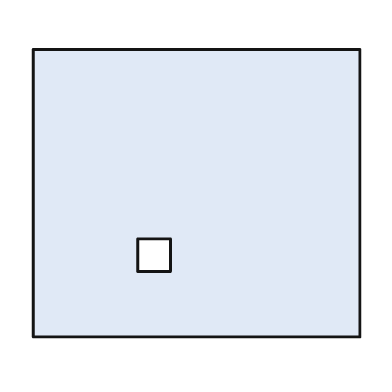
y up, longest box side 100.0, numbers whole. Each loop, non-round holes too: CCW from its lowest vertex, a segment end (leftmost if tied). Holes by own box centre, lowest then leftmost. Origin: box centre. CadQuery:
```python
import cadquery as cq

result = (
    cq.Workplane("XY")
    .moveTo(-50.0, -44.0)
    .lineTo(50.0, -44.0)
    .lineTo(50.0, 44.0)
    .lineTo(-50.0, 44.0)
    .close()
    .moveTo(-18.0, -24.0)
    .lineTo(-8.0, -24.0)
    .lineTo(-8.0, -14.0)
    .lineTo(-18.0, -14.0)
    .close()
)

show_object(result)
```